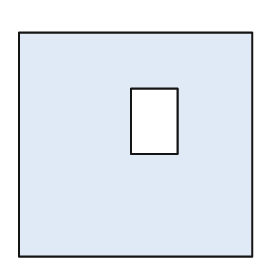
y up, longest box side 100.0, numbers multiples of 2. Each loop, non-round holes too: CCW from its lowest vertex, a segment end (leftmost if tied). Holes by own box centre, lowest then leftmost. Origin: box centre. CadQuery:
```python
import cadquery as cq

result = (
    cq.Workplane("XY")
    .moveTo(-50.0, -48.0)
    .lineTo(50.0, -48.0)
    .lineTo(50.0, 48.0)
    .lineTo(-50.0, 48.0)
    .close()
    .moveTo(-2.0, -4.0)
    .lineTo(18.0, -4.0)
    .lineTo(18.0, 24.0)
    .lineTo(-2.0, 24.0)
    .close()
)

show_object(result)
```